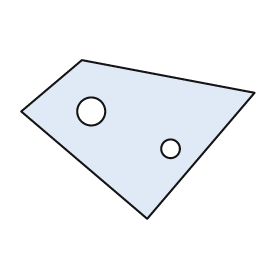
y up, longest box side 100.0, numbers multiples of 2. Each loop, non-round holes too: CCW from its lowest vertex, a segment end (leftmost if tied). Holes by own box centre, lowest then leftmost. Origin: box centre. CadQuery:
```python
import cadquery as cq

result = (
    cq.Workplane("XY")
    .moveTo(4.0, -34.0)
    .lineTo(50.0, 20.0)
    .lineTo(-24.0, 34.0)
    .lineTo(-50.0, 12.0)
    .close()
    .moveTo(14.0, -4.0)
    .circle(4.0)
    .moveTo(-20.0, 12.0)
    .circle(6.0)
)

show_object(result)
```